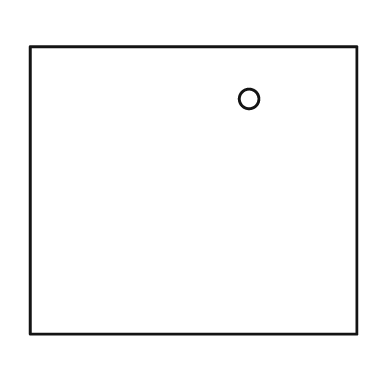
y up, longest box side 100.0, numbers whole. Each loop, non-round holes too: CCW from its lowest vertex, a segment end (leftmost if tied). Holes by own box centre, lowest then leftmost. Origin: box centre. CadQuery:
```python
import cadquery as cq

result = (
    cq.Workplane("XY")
    .moveTo(-50.0, -44.0)
    .lineTo(50.0, -44.0)
    .lineTo(50.0, 44.0)
    .lineTo(-50.0, 44.0)
    .close()
    .moveTo(17.0, 28.0)
    .circle(3.0)
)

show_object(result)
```